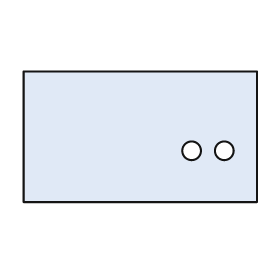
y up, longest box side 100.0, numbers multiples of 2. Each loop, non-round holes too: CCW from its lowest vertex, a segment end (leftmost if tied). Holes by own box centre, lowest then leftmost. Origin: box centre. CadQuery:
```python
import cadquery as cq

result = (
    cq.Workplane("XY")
    .moveTo(-50.0, -28.0)
    .lineTo(50.0, -28.0)
    .lineTo(50.0, 28.0)
    .lineTo(-50.0, 28.0)
    .close()
    .moveTo(22.0, -6.0)
    .circle(4.0)
    .moveTo(36.0, -6.0)
    .circle(4.0)
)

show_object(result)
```